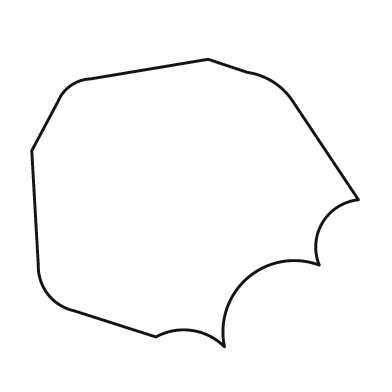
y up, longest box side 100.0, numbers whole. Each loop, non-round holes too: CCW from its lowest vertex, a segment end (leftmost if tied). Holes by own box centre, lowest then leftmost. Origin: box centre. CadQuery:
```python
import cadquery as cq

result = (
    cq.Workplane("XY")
    .moveTo(9.0, -44.0)
    .threePointArc((16.0, -23.0), (38.0, -19.0))
    .threePointArc((39.0, -6.0), (50.0, 1.0))
    .lineTo(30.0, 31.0)
    .threePointArc((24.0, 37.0), (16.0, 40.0))
    .lineTo(4.0, 44.0)
    .lineTo(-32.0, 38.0)
    .threePointArc((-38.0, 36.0), (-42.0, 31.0))
    .lineTo(-50.0, 16.0)
    .lineTo(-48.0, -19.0)
    .threePointArc((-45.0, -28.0), (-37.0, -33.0))
    .lineTo(-12.0, -41.0)
    .threePointArc((-1.0, -39.0), (9.0, -44.0))
    .close()
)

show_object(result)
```